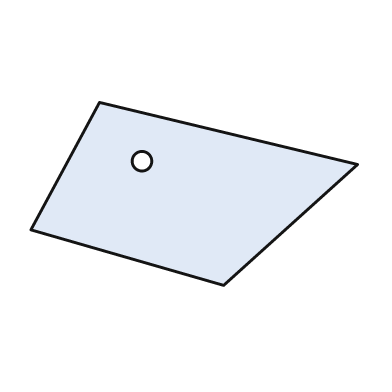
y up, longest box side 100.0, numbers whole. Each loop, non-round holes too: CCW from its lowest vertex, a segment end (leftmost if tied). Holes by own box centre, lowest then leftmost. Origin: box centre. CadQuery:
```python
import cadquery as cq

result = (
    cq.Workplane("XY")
    .moveTo(9.0, -28.0)
    .lineTo(50.0, 9.0)
    .lineTo(-29.0, 28.0)
    .lineTo(-50.0, -11.0)
    .close()
    .moveTo(-16.0, 10.0)
    .circle(3.0)
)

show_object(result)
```